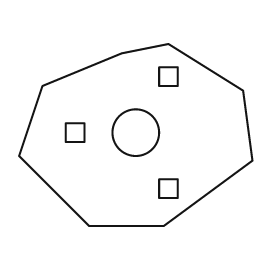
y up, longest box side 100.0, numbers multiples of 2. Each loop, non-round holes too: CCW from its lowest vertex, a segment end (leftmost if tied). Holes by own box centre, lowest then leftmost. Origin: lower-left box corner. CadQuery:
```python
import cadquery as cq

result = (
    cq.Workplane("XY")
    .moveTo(30.0, 0.0)
    .lineTo(62.0, 0.0)
    .lineTo(100.0, 28.0)
    .lineTo(96.0, 58.0)
    .lineTo(64.0, 78.0)
    .lineTo(44.0, 74.0)
    .lineTo(10.0, 60.0)
    .lineTo(0.0, 30.0)
    .close()
    .moveTo(60.0, 12.0)
    .lineTo(68.0, 12.0)
    .lineTo(68.0, 20.0)
    .lineTo(60.0, 20.0)
    .close()
    .moveTo(20.0, 36.0)
    .lineTo(28.0, 36.0)
    .lineTo(28.0, 44.0)
    .lineTo(20.0, 44.0)
    .close()
    .moveTo(50.0, 40.0)
    .circle(10.0)
    .moveTo(60.0, 60.0)
    .lineTo(68.0, 60.0)
    .lineTo(68.0, 68.0)
    .lineTo(60.0, 68.0)
    .close()
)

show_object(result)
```